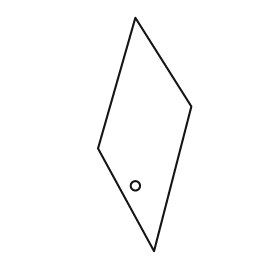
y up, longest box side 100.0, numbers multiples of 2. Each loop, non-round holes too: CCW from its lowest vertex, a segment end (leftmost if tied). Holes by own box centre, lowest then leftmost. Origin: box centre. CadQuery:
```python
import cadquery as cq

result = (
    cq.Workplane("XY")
    .moveTo(4.0, -50.0)
    .lineTo(20.0, 12.0)
    .lineTo(-4.0, 50.0)
    .lineTo(-20.0, -6.0)
    .close()
    .moveTo(-4.0, -22.0)
    .circle(2.0)
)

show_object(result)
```